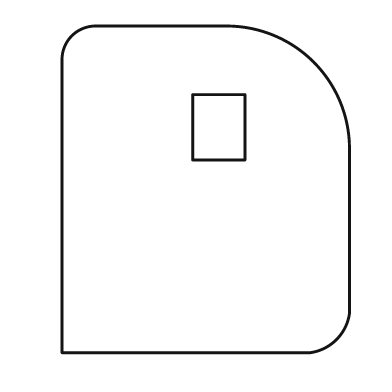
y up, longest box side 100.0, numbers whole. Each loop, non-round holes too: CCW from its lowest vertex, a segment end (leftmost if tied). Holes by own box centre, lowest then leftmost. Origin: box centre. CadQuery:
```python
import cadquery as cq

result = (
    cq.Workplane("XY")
    .moveTo(-44.0, -50.0)
    .lineTo(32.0, -50.0)
    .threePointArc((40.0, -46.0), (44.0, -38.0))
    .lineTo(44.0, 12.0)
    .threePointArc((33.0, 39.0), (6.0, 50.0))
    .lineTo(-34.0, 50.0)
    .threePointArc((-41.0, 47.0), (-44.0, 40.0))
    .close()
    .moveTo(-4.0, 9.0)
    .lineTo(12.0, 9.0)
    .lineTo(12.0, 29.0)
    .lineTo(-4.0, 29.0)
    .close()
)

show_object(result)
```